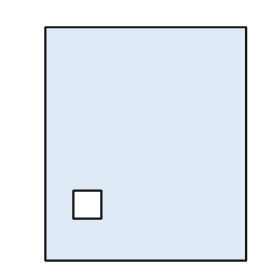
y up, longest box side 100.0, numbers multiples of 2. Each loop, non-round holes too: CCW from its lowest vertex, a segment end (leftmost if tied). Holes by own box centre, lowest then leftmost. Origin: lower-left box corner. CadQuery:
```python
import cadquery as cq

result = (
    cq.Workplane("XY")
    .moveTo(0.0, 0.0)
    .lineTo(86.0, 0.0)
    .lineTo(86.0, 100.0)
    .lineTo(0.0, 100.0)
    .close()
    .moveTo(12.0, 18.0)
    .lineTo(24.0, 18.0)
    .lineTo(24.0, 30.0)
    .lineTo(12.0, 30.0)
    .close()
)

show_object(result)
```